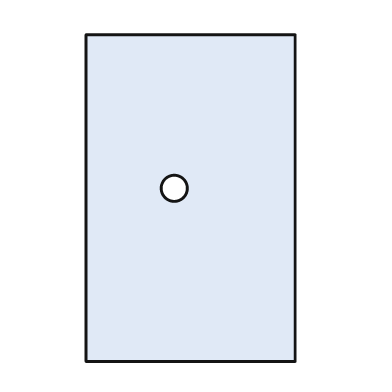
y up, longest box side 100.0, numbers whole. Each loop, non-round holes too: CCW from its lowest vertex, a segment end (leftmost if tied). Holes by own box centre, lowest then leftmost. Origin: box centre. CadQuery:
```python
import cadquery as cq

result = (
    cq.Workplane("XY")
    .moveTo(-32.0, -50.0)
    .lineTo(32.0, -50.0)
    .lineTo(32.0, 50.0)
    .lineTo(-32.0, 50.0)
    .close()
    .moveTo(-5.0, 3.0)
    .circle(4.0)
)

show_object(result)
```